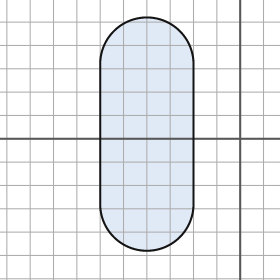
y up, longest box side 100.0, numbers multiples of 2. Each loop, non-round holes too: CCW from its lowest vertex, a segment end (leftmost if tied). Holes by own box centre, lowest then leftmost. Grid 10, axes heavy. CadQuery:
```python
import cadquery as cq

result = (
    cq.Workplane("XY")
    .moveTo(-60.0, -28.0)
    .threePointArc((-40.0, -48.0), (-20.0, -28.0))
    .lineTo(-20.0, 32.0)
    .threePointArc((-40.0, 52.0), (-60.0, 32.0))
    .close()
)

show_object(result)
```